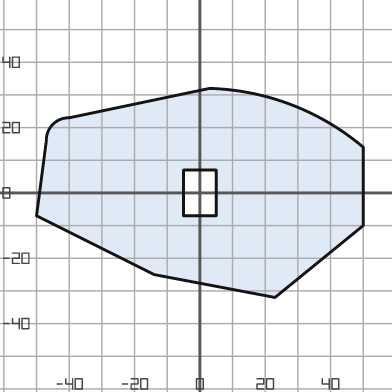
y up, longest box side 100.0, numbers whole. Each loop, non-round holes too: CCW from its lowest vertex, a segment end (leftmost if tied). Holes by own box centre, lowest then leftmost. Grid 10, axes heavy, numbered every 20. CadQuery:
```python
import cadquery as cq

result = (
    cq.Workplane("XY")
    .moveTo(23.0, -32.0)
    .lineTo(50.0, -10.0)
    .lineTo(50.0, 14.0)
    .threePointArc((28.0, 27.0), (3.0, 32.0))
    .lineTo(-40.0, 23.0)
    .threePointArc((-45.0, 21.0), (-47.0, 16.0))
    .lineTo(-50.0, -7.0)
    .lineTo(-14.0, -25.0)
    .close()
    .moveTo(-5.0, -7.0)
    .lineTo(5.0, -7.0)
    .lineTo(5.0, 7.0)
    .lineTo(-5.0, 7.0)
    .close()
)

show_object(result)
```